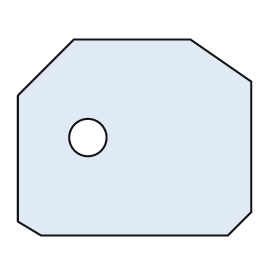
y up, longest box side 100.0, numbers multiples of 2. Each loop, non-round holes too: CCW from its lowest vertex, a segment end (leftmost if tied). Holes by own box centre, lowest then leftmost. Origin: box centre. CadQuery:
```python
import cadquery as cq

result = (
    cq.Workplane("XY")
    .moveTo(-40.0, -42.0)
    .lineTo(40.0, -42.0)
    .lineTo(50.0, -32.0)
    .lineTo(50.0, 24.0)
    .lineTo(24.0, 42.0)
    .lineTo(-26.0, 42.0)
    .lineTo(-50.0, 18.0)
    .lineTo(-50.0, -36.0)
    .close()
    .moveTo(-20.0, 0.0)
    .circle(8.0)
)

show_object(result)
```